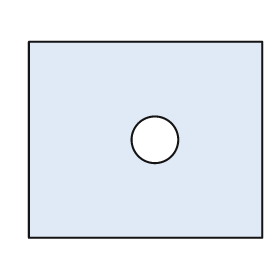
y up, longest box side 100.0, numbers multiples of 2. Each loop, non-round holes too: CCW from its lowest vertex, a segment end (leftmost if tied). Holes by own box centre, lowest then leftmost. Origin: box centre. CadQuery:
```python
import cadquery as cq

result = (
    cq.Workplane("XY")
    .moveTo(-50.0, -42.0)
    .lineTo(50.0, -42.0)
    .lineTo(50.0, 42.0)
    .lineTo(-50.0, 42.0)
    .close()
    .moveTo(4.0, 0.0)
    .circle(10.0)
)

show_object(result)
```